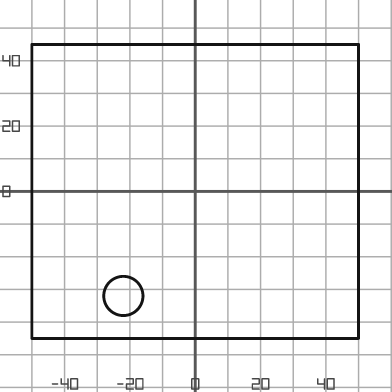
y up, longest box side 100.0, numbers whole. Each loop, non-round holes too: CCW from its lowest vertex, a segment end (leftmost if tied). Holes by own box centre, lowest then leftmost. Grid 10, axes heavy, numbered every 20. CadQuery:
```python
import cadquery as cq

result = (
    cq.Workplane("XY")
    .moveTo(-50.0, -45.0)
    .lineTo(50.0, -45.0)
    .lineTo(50.0, 45.0)
    .lineTo(-50.0, 45.0)
    .close()
    .moveTo(-22.0, -32.0)
    .circle(6.0)
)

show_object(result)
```